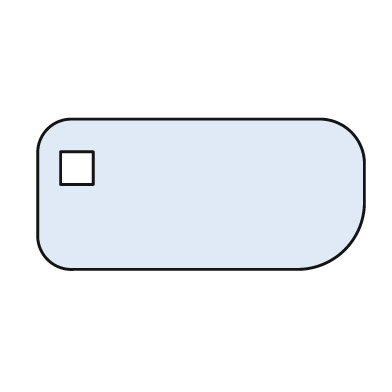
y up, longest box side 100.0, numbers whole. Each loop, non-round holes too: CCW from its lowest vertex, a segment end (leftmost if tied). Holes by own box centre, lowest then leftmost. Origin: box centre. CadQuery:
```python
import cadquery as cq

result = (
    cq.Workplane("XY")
    .moveTo(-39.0, -23.0)
    .lineTo(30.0, -23.0)
    .threePointArc((44.0, -17.0), (50.0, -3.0))
    .lineTo(50.0, 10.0)
    .threePointArc((46.0, 19.0), (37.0, 23.0))
    .lineTo(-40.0, 23.0)
    .threePointArc((-47.0, 20.0), (-50.0, 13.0))
    .lineTo(-50.0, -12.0)
    .threePointArc((-47.0, -20.0), (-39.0, -23.0))
    .close()
    .moveTo(-43.0, 3.0)
    .lineTo(-33.0, 3.0)
    .lineTo(-33.0, 13.0)
    .lineTo(-43.0, 13.0)
    .close()
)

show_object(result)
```